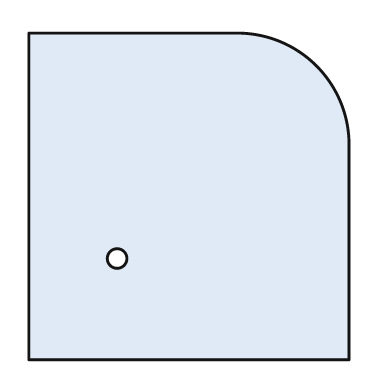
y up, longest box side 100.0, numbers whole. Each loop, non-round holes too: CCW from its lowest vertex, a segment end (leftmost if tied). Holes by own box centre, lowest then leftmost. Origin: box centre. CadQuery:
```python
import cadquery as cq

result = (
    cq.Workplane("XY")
    .moveTo(-49.0, -50.0)
    .lineTo(49.0, -50.0)
    .lineTo(49.0, 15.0)
    .threePointArc((39.0, 40.0), (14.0, 50.0))
    .lineTo(-49.0, 50.0)
    .close()
    .moveTo(-22.0, -19.0)
    .circle(3.0)
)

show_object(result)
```